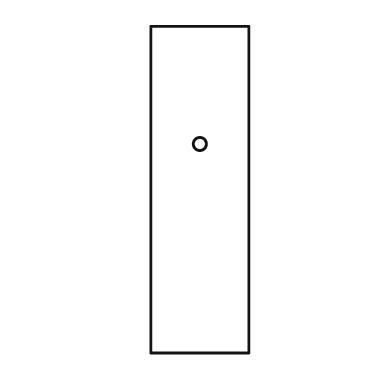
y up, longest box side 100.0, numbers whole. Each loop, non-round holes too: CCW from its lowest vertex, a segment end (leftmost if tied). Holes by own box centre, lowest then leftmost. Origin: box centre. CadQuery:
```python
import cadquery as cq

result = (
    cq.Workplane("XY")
    .moveTo(-15.0, -50.0)
    .lineTo(15.0, -50.0)
    .lineTo(15.0, 50.0)
    .lineTo(-15.0, 50.0)
    .close()
    .moveTo(0.0, 14.0)
    .circle(2.0)
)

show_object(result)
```